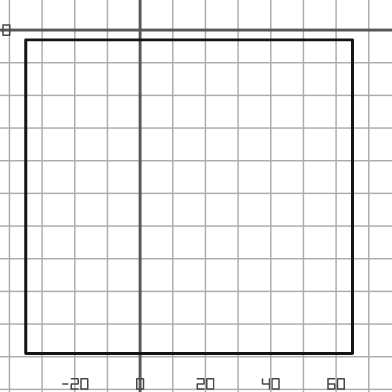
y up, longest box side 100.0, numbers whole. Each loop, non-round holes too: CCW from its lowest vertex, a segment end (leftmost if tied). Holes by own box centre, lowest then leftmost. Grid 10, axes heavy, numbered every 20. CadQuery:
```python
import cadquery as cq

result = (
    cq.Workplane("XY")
    .moveTo(-35.0, -99.0)
    .lineTo(65.0, -99.0)
    .lineTo(65.0, -3.0)
    .lineTo(-35.0, -3.0)
    .close()
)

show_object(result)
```